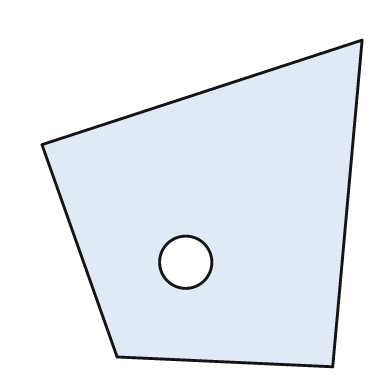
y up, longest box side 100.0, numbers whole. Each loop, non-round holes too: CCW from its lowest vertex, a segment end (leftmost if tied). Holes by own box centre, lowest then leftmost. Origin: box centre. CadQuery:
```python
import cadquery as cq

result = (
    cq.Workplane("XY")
    .moveTo(40.0, -50.0)
    .lineTo(49.0, 50.0)
    .lineTo(-49.0, 18.0)
    .lineTo(-26.0, -47.0)
    .close()
    .moveTo(-5.0, -18.0)
    .circle(8.0)
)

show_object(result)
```